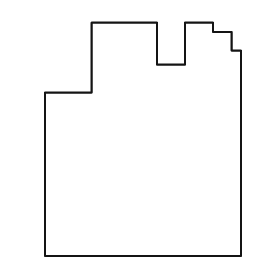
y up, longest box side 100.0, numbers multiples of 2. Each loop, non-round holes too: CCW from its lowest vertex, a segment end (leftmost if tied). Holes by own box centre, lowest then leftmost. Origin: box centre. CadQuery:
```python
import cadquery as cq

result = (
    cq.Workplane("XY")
    .moveTo(-42.0, -50.0)
    .lineTo(42.0, -50.0)
    .lineTo(42.0, 38.0)
    .lineTo(38.0, 38.0)
    .lineTo(38.0, 46.0)
    .lineTo(30.0, 46.0)
    .lineTo(30.0, 50.0)
    .lineTo(18.0, 50.0)
    .lineTo(18.0, 32.0)
    .lineTo(6.0, 32.0)
    .lineTo(6.0, 50.0)
    .lineTo(-22.0, 50.0)
    .lineTo(-22.0, 20.0)
    .lineTo(-42.0, 20.0)
    .close()
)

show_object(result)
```